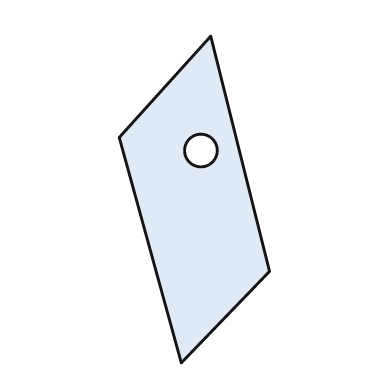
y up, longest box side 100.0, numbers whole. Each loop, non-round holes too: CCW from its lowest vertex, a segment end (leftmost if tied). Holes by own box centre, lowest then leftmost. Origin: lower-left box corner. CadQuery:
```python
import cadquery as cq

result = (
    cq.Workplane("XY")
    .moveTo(19.0, 0.0)
    .lineTo(46.0, 28.0)
    .lineTo(28.0, 100.0)
    .lineTo(0.0, 69.0)
    .close()
    .moveTo(25.0, 65.0)
    .circle(5.0)
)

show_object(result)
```